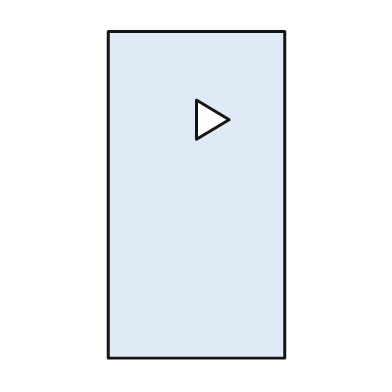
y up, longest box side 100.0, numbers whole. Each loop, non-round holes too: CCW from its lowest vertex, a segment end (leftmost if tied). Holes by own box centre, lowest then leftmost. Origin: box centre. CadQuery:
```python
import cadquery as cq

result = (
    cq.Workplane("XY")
    .moveTo(-27.0, -50.0)
    .lineTo(27.0, -50.0)
    .lineTo(27.0, 50.0)
    .lineTo(-27.0, 50.0)
    .close()
    .moveTo(0.0, 17.0)
    .lineTo(10.0, 23.0)
    .lineTo(0.0, 29.0)
    .close()
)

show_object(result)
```